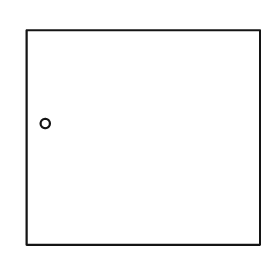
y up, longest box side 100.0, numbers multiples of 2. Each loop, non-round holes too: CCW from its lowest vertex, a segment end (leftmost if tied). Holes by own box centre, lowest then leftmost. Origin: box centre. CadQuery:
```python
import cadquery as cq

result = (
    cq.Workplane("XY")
    .moveTo(-50.0, -46.0)
    .lineTo(50.0, -46.0)
    .lineTo(50.0, 46.0)
    .lineTo(-50.0, 46.0)
    .close()
    .moveTo(-42.0, 6.0)
    .circle(2.0)
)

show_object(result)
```